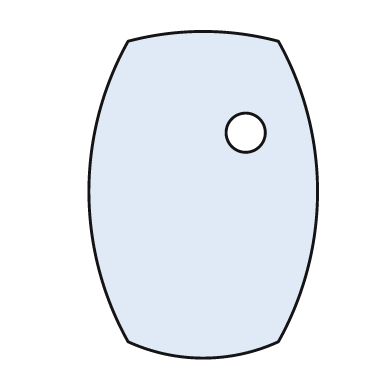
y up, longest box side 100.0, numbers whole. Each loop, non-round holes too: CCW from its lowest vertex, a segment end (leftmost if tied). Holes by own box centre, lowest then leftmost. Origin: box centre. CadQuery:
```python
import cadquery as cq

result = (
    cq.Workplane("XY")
    .moveTo(-23.0, -45.0)
    .threePointArc((0.0, -50.0), (23.0, -45.0))
    .threePointArc((35.0, 1.0), (23.0, 47.0))
    .threePointArc((0.0, 50.0), (-23.0, 47.0))
    .threePointArc((-35.0, 1.0), (-23.0, -45.0))
    .close()
    .moveTo(13.0, 19.0)
    .circle(6.0)
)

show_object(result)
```